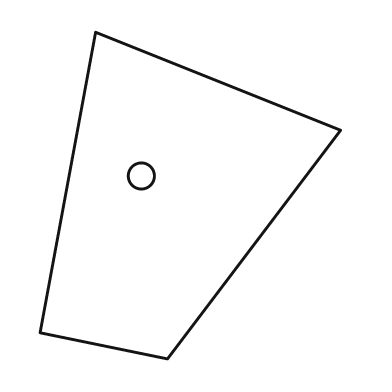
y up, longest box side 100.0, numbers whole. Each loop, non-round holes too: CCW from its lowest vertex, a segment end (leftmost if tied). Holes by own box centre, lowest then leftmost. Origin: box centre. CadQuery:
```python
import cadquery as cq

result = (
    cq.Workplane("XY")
    .moveTo(-7.0, -50.0)
    .lineTo(46.0, 20.0)
    .lineTo(-29.0, 50.0)
    .lineTo(-46.0, -42.0)
    .close()
    .moveTo(-15.0, 6.0)
    .circle(4.0)
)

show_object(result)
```